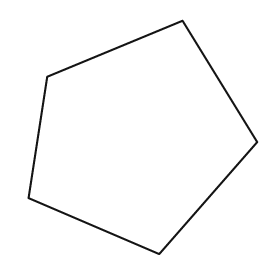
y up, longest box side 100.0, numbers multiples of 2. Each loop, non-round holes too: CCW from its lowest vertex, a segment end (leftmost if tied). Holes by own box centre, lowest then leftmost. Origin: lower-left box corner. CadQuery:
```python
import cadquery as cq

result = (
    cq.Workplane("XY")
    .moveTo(56.0, 0.0)
    .lineTo(98.0, 48.0)
    .lineTo(66.0, 100.0)
    .lineTo(8.0, 76.0)
    .lineTo(0.0, 24.0)
    .close()
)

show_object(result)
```